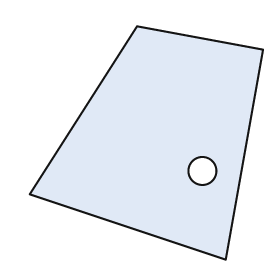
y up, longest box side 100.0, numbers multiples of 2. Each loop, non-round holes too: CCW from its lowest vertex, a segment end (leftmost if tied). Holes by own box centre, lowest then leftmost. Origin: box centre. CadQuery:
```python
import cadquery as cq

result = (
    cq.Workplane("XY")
    .moveTo(34.0, -50.0)
    .lineTo(50.0, 40.0)
    .lineTo(-4.0, 50.0)
    .lineTo(-50.0, -22.0)
    .close()
    .moveTo(24.0, -12.0)
    .circle(6.0)
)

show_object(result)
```